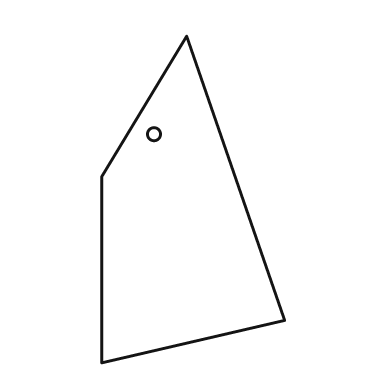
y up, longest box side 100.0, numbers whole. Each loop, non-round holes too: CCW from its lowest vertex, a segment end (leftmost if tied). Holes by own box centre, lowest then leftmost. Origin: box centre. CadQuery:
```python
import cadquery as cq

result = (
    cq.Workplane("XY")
    .moveTo(-28.0, -50.0)
    .lineTo(28.0, -37.0)
    .lineTo(-2.0, 50.0)
    .lineTo(-28.0, 7.0)
    .close()
    .moveTo(-12.0, 20.0)
    .circle(2.0)
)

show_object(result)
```